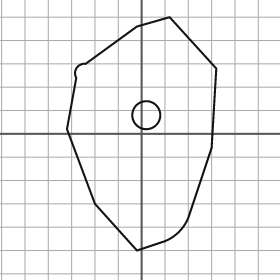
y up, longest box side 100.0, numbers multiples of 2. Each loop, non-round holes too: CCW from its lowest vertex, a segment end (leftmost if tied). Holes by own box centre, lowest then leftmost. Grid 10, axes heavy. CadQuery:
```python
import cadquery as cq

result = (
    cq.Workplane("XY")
    .moveTo(-2.0, -50.0)
    .lineTo(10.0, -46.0)
    .threePointArc((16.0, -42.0), (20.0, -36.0))
    .lineTo(30.0, -6.0)
    .lineTo(32.0, 28.0)
    .lineTo(12.0, 50.0)
    .lineTo(-2.0, 46.0)
    .lineTo(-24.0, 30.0)
    .threePointArc((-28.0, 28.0), (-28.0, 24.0))
    .lineTo(-32.0, 2.0)
    .lineTo(-20.0, -30.0)
    .close()
    .moveTo(2.0, 8.0)
    .circle(6.0)
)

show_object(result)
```